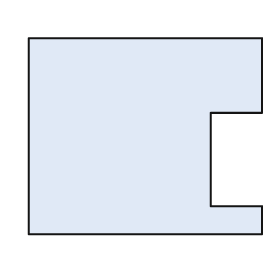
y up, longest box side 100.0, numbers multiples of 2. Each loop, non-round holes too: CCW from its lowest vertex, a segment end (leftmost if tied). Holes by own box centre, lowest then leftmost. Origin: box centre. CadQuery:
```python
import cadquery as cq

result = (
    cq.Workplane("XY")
    .moveTo(-50.0, -42.0)
    .lineTo(50.0, -42.0)
    .lineTo(50.0, -30.0)
    .lineTo(28.0, -30.0)
    .lineTo(28.0, 10.0)
    .lineTo(50.0, 10.0)
    .lineTo(50.0, 42.0)
    .lineTo(-50.0, 42.0)
    .close()
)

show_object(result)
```